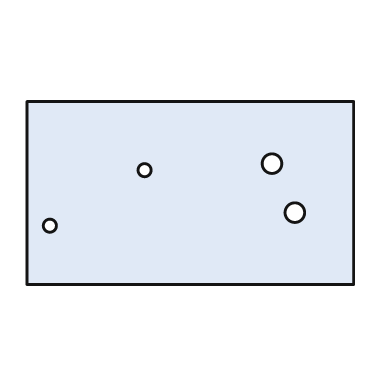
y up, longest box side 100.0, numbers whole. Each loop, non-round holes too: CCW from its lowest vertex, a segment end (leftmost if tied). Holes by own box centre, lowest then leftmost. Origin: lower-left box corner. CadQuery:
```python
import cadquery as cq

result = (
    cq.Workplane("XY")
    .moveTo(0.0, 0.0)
    .lineTo(100.0, 0.0)
    .lineTo(100.0, 56.0)
    .lineTo(0.0, 56.0)
    .close()
    .moveTo(7.0, 18.0)
    .circle(2.0)
    .moveTo(82.0, 22.0)
    .circle(3.0)
    .moveTo(36.0, 35.0)
    .circle(2.0)
    .moveTo(75.0, 37.0)
    .circle(3.0)
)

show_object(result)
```